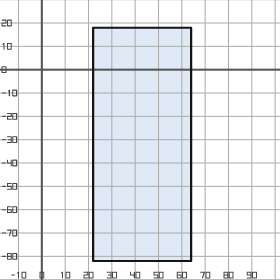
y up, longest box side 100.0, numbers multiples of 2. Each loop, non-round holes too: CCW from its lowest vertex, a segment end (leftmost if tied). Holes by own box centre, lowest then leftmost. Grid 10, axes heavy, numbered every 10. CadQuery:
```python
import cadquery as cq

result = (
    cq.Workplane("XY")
    .moveTo(22.0, -82.0)
    .lineTo(64.0, -82.0)
    .lineTo(64.0, 18.0)
    .lineTo(22.0, 18.0)
    .close()
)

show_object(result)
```